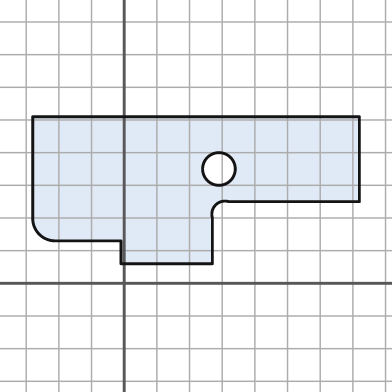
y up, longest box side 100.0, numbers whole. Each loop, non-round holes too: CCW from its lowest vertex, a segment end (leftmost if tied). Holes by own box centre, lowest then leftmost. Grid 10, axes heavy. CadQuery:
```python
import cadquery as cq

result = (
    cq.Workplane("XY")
    .moveTo(-1.0, 6.0)
    .lineTo(27.0, 6.0)
    .lineTo(27.0, 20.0)
    .threePointArc((28.0, 24.0), (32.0, 25.0))
    .lineTo(72.0, 25.0)
    .lineTo(72.0, 51.0)
    .lineTo(-28.0, 51.0)
    .lineTo(-28.0, 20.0)
    .threePointArc((-26.0, 15.0), (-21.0, 13.0))
    .lineTo(-1.0, 13.0)
    .close()
    .moveTo(29.0, 35.0)
    .circle(5.0)
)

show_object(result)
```